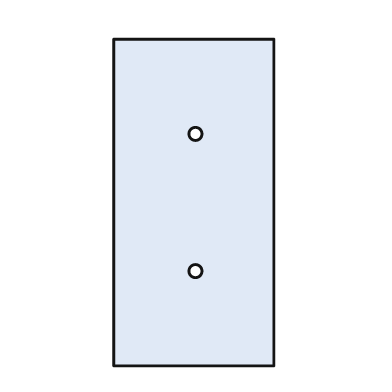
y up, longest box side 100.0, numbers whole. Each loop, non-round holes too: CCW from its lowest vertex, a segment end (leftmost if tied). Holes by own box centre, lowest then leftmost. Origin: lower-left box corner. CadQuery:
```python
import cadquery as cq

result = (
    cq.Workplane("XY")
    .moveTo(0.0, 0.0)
    .lineTo(49.0, 0.0)
    .lineTo(49.0, 100.0)
    .lineTo(0.0, 100.0)
    .close()
    .moveTo(25.0, 29.0)
    .circle(2.0)
    .moveTo(25.0, 71.0)
    .circle(2.0)
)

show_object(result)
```